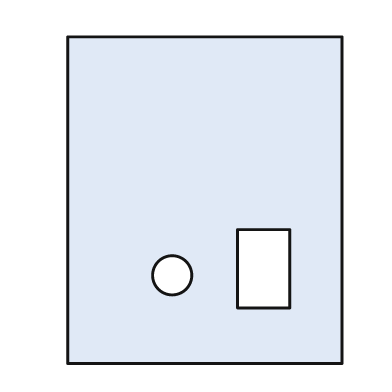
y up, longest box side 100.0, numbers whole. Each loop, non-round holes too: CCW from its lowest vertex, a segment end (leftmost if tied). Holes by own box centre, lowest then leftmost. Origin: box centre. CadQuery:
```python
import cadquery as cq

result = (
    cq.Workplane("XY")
    .moveTo(-42.0, -50.0)
    .lineTo(42.0, -50.0)
    .lineTo(42.0, 50.0)
    .lineTo(-42.0, 50.0)
    .close()
    .moveTo(-10.0, -23.0)
    .circle(6.0)
    .moveTo(10.0, -33.0)
    .lineTo(26.0, -33.0)
    .lineTo(26.0, -9.0)
    .lineTo(10.0, -9.0)
    .close()
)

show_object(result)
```